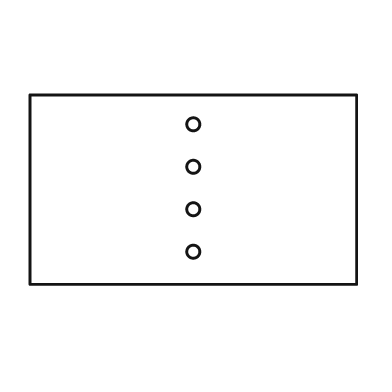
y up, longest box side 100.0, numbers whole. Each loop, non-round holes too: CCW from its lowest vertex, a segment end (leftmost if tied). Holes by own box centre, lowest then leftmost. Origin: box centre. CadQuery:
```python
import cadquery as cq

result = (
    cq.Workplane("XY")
    .moveTo(-50.0, -29.0)
    .lineTo(50.0, -29.0)
    .lineTo(50.0, 29.0)
    .lineTo(-50.0, 29.0)
    .close()
    .moveTo(0.0, -19.0)
    .circle(2.0)
    .moveTo(0.0, -6.0)
    .circle(2.0)
    .moveTo(0.0, 7.0)
    .circle(2.0)
    .moveTo(0.0, 20.0)
    .circle(2.0)
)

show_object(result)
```